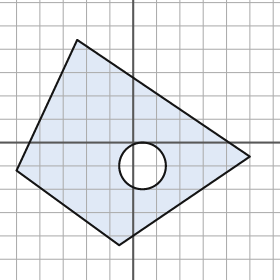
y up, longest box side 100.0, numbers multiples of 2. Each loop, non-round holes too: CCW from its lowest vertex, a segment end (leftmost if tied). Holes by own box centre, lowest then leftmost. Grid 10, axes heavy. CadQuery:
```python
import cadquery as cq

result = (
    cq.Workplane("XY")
    .moveTo(-6.0, -44.0)
    .lineTo(50.0, -6.0)
    .lineTo(-24.0, 44.0)
    .lineTo(-50.0, -12.0)
    .close()
    .moveTo(4.0, -10.0)
    .circle(10.0)
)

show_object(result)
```